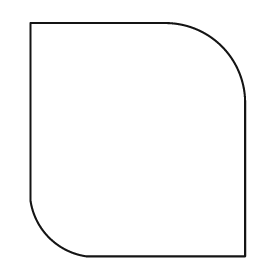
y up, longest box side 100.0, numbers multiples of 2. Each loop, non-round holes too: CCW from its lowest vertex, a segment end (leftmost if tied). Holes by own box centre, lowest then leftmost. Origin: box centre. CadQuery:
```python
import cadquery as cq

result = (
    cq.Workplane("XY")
    .moveTo(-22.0, -50.0)
    .lineTo(46.0, -50.0)
    .lineTo(46.0, 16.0)
    .threePointArc((36.0, 40.0), (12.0, 50.0))
    .lineTo(-46.0, 50.0)
    .lineTo(-46.0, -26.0)
    .threePointArc((-38.0, -42.0), (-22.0, -50.0))
    .close()
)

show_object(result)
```